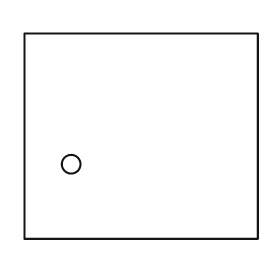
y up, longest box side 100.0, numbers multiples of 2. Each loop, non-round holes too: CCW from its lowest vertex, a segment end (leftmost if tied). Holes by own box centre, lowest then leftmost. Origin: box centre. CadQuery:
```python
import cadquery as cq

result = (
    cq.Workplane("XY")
    .moveTo(-50.0, -44.0)
    .lineTo(50.0, -44.0)
    .lineTo(50.0, 44.0)
    .lineTo(-50.0, 44.0)
    .close()
    .moveTo(-30.0, -12.0)
    .circle(4.0)
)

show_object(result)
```